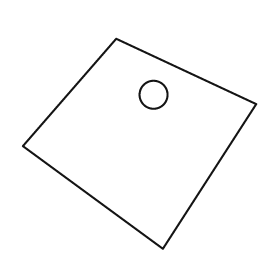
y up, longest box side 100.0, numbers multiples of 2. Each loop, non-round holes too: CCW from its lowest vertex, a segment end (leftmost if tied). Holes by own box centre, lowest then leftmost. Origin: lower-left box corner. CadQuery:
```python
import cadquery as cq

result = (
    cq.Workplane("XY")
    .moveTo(60.0, 0.0)
    .lineTo(100.0, 62.0)
    .lineTo(40.0, 90.0)
    .lineTo(0.0, 44.0)
    .close()
    .moveTo(56.0, 66.0)
    .circle(6.0)
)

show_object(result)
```